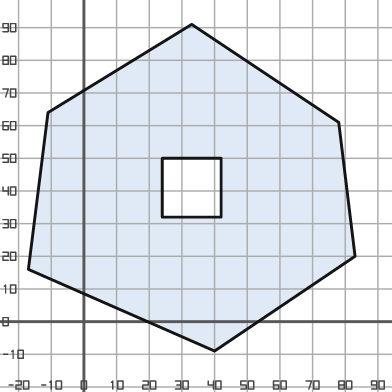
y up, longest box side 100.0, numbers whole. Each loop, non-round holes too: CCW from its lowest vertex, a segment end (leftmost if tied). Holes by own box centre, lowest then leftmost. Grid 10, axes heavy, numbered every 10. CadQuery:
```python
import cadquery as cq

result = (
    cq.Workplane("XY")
    .moveTo(40.0, -9.0)
    .lineTo(83.0, 20.0)
    .lineTo(78.0, 61.0)
    .lineTo(33.0, 91.0)
    .lineTo(-11.0, 64.0)
    .lineTo(-17.0, 16.0)
    .close()
    .moveTo(24.0, 32.0)
    .lineTo(42.0, 32.0)
    .lineTo(42.0, 50.0)
    .lineTo(24.0, 50.0)
    .close()
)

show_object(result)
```